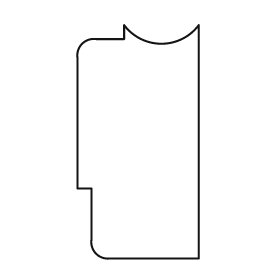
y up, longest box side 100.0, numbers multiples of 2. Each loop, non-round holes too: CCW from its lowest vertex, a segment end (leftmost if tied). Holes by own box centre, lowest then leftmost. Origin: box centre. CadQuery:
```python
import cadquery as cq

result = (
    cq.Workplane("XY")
    .moveTo(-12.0, -50.0)
    .lineTo(26.0, -50.0)
    .lineTo(26.0, 50.0)
    .threePointArc((10.0, 42.0), (-6.0, 50.0))
    .lineTo(-6.0, 44.0)
    .lineTo(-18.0, 44.0)
    .threePointArc((-24.0, 42.0), (-26.0, 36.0))
    .lineTo(-26.0, -20.0)
    .lineTo(-20.0, -20.0)
    .lineTo(-20.0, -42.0)
    .threePointArc((-18.0, -48.0), (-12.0, -50.0))
    .close()
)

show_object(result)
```